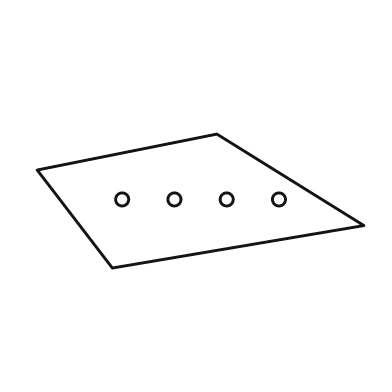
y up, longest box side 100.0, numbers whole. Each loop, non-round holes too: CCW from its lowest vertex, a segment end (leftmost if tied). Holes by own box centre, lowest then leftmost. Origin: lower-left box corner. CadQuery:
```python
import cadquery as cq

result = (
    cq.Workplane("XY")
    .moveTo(23.0, 0.0)
    .lineTo(100.0, 13.0)
    .lineTo(55.0, 41.0)
    .lineTo(0.0, 30.0)
    .close()
    .moveTo(26.0, 21.0)
    .circle(2.0)
    .moveTo(42.0, 21.0)
    .circle(2.0)
    .moveTo(58.0, 21.0)
    .circle(2.0)
    .moveTo(74.0, 21.0)
    .circle(2.0)
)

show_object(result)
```